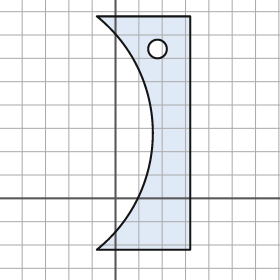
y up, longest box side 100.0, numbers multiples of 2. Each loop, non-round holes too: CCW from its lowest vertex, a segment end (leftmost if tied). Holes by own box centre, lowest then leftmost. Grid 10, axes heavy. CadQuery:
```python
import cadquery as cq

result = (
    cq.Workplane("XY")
    .moveTo(-8.0, -22.0)
    .lineTo(32.0, -22.0)
    .lineTo(32.0, 78.0)
    .lineTo(-8.0, 78.0)
    .threePointArc((16.0, 28.0), (-8.0, -22.0))
    .close()
    .moveTo(18.0, 64.0)
    .circle(4.0)
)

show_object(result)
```